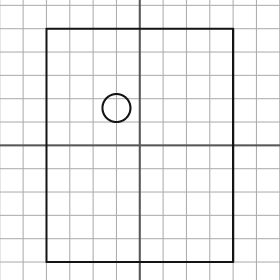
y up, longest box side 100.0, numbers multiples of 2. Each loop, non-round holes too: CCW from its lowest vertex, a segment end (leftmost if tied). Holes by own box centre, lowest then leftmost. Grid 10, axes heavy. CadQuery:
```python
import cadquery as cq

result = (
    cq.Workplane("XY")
    .moveTo(-40.0, -50.0)
    .lineTo(40.0, -50.0)
    .lineTo(40.0, 50.0)
    .lineTo(-40.0, 50.0)
    .close()
    .moveTo(-10.0, 16.0)
    .circle(6.0)
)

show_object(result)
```